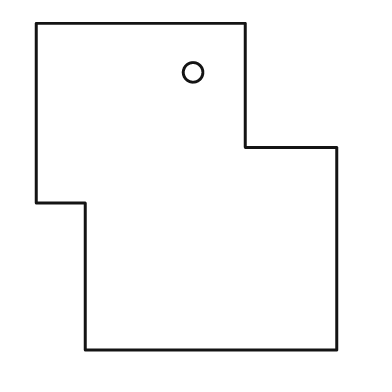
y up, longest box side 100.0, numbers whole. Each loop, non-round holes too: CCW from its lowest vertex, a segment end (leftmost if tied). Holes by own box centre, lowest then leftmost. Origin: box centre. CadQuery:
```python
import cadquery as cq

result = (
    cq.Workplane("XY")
    .moveTo(-31.0, -50.0)
    .lineTo(46.0, -50.0)
    .lineTo(46.0, 12.0)
    .lineTo(18.0, 12.0)
    .lineTo(18.0, 50.0)
    .lineTo(-46.0, 50.0)
    .lineTo(-46.0, -5.0)
    .lineTo(-31.0, -5.0)
    .close()
    .moveTo(2.0, 35.0)
    .circle(3.0)
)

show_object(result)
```